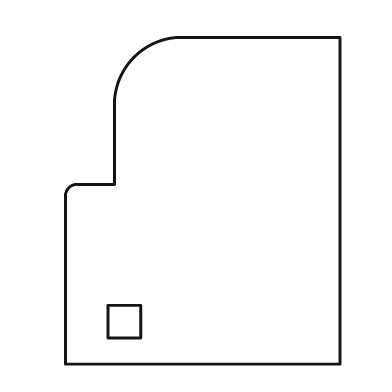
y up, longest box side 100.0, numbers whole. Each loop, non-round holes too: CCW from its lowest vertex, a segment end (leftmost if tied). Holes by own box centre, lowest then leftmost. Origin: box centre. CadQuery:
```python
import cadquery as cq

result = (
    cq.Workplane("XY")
    .moveTo(-42.0, -50.0)
    .lineTo(42.0, -50.0)
    .lineTo(42.0, 50.0)
    .lineTo(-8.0, 50.0)
    .threePointArc((-21.0, 44.0), (-27.0, 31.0))
    .lineTo(-27.0, 5.0)
    .lineTo(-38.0, 5.0)
    .threePointArc((-41.0, 4.0), (-42.0, 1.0))
    .close()
    .moveTo(-29.0, -42.0)
    .lineTo(-19.0, -42.0)
    .lineTo(-19.0, -32.0)
    .lineTo(-29.0, -32.0)
    .close()
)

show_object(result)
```